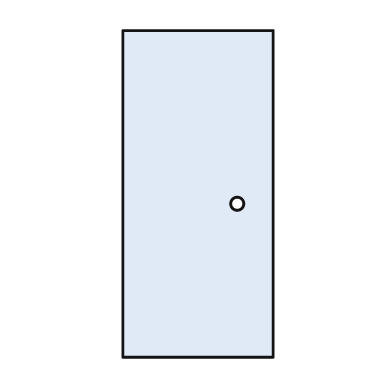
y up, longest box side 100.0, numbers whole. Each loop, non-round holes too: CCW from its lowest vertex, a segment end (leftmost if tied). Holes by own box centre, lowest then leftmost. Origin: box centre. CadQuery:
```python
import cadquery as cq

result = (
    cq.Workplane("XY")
    .moveTo(-23.0, -50.0)
    .lineTo(23.0, -50.0)
    .lineTo(23.0, 50.0)
    .lineTo(-23.0, 50.0)
    .close()
    .moveTo(12.0, -3.0)
    .circle(2.0)
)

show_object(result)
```